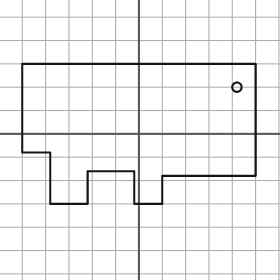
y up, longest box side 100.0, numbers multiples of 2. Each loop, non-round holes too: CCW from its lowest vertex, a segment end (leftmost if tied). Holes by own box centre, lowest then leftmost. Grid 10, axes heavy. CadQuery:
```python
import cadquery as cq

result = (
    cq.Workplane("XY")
    .moveTo(-38.0, -30.0)
    .lineTo(-22.0, -30.0)
    .lineTo(-22.0, -16.0)
    .lineTo(-2.0, -16.0)
    .lineTo(-2.0, -30.0)
    .lineTo(10.0, -30.0)
    .lineTo(10.0, -18.0)
    .lineTo(50.0, -18.0)
    .lineTo(50.0, 30.0)
    .lineTo(-50.0, 30.0)
    .lineTo(-50.0, -8.0)
    .lineTo(-38.0, -8.0)
    .close()
    .moveTo(42.0, 20.0)
    .circle(2.0)
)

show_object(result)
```